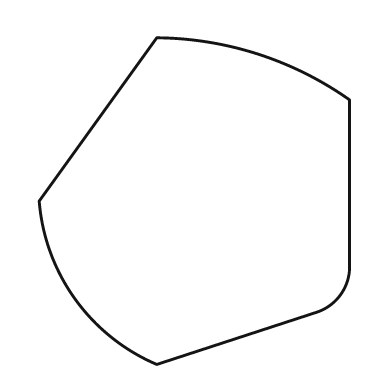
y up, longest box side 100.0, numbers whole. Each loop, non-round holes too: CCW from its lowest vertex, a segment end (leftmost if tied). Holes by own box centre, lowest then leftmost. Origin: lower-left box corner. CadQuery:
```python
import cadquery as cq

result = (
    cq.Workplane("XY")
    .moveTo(36.0, 0.0)
    .lineTo(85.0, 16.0)
    .threePointArc((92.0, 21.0), (95.0, 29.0))
    .lineTo(95.0, 81.0)
    .threePointArc((67.0, 95.0), (36.0, 100.0))
    .lineTo(0.0, 50.0)
    .threePointArc((11.0, 20.0), (36.0, 0.0))
    .close()
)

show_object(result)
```